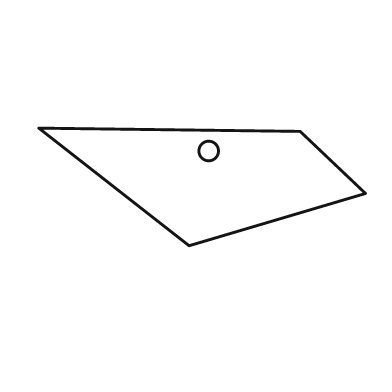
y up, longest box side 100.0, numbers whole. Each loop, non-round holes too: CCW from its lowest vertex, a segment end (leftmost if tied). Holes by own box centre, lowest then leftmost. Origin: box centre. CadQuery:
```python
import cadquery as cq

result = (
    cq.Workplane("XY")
    .moveTo(-4.0, -18.0)
    .lineTo(50.0, -2.0)
    .lineTo(30.0, 17.0)
    .lineTo(-50.0, 18.0)
    .close()
    .moveTo(2.0, 11.0)
    .circle(3.0)
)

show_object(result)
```